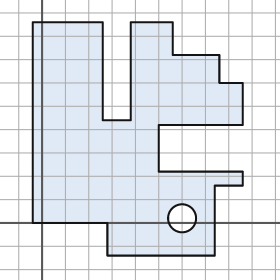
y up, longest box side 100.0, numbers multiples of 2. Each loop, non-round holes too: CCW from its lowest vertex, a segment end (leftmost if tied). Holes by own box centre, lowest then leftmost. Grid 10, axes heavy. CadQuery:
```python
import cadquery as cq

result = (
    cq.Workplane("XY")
    .moveTo(28.0, -14.0)
    .lineTo(74.0, -14.0)
    .lineTo(74.0, 16.0)
    .lineTo(86.0, 16.0)
    .lineTo(86.0, 22.0)
    .lineTo(50.0, 22.0)
    .lineTo(50.0, 42.0)
    .lineTo(86.0, 42.0)
    .lineTo(86.0, 60.0)
    .lineTo(76.0, 60.0)
    .lineTo(76.0, 72.0)
    .lineTo(56.0, 72.0)
    .lineTo(56.0, 86.0)
    .lineTo(38.0, 86.0)
    .lineTo(38.0, 44.0)
    .lineTo(26.0, 44.0)
    .lineTo(26.0, 86.0)
    .lineTo(-4.0, 86.0)
    .lineTo(-4.0, 0.0)
    .lineTo(28.0, 0.0)
    .close()
    .moveTo(60.0, 2.0)
    .circle(6.0)
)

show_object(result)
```